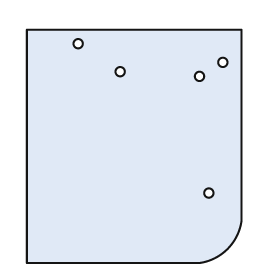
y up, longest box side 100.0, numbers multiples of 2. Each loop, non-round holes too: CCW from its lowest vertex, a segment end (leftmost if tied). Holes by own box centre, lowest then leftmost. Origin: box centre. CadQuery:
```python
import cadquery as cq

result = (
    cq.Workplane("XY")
    .moveTo(-46.0, -50.0)
    .lineTo(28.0, -50.0)
    .threePointArc((40.0, -44.0), (46.0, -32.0))
    .lineTo(46.0, 50.0)
    .lineTo(-46.0, 50.0)
    .close()
    .moveTo(32.0, -20.0)
    .circle(2.0)
    .moveTo(28.0, 30.0)
    .circle(2.0)
    .moveTo(-6.0, 32.0)
    .circle(2.0)
    .moveTo(38.0, 36.0)
    .circle(2.0)
    .moveTo(-24.0, 44.0)
    .circle(2.0)
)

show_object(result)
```